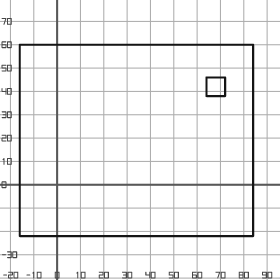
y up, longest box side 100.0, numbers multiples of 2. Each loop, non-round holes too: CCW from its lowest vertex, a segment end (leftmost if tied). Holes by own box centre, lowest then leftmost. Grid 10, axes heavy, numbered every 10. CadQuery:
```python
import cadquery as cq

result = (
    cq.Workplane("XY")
    .moveTo(-16.0, -22.0)
    .lineTo(84.0, -22.0)
    .lineTo(84.0, 60.0)
    .lineTo(-16.0, 60.0)
    .close()
    .moveTo(64.0, 38.0)
    .lineTo(72.0, 38.0)
    .lineTo(72.0, 46.0)
    .lineTo(64.0, 46.0)
    .close()
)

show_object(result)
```